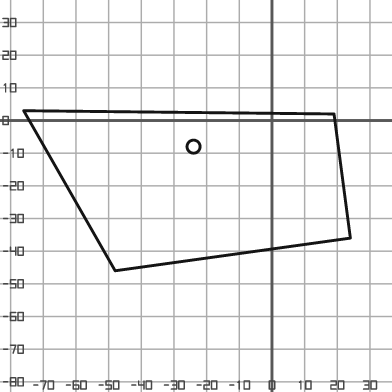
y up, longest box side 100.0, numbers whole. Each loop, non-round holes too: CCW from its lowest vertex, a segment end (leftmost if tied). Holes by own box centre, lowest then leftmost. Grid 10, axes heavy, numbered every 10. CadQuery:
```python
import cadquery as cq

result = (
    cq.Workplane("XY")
    .moveTo(-48.0, -46.0)
    .lineTo(24.0, -36.0)
    .lineTo(19.0, 2.0)
    .lineTo(-76.0, 3.0)
    .close()
    .moveTo(-24.0, -8.0)
    .circle(2.0)
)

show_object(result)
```